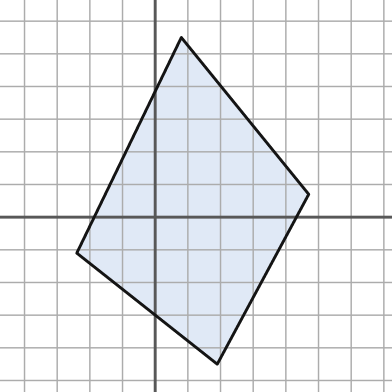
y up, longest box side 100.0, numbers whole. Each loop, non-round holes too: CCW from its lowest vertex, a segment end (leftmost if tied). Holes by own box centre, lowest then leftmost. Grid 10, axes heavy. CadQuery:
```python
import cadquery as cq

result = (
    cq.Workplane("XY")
    .moveTo(19.0, -45.0)
    .lineTo(47.0, 7.0)
    .lineTo(8.0, 55.0)
    .lineTo(-24.0, -11.0)
    .close()
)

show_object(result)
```